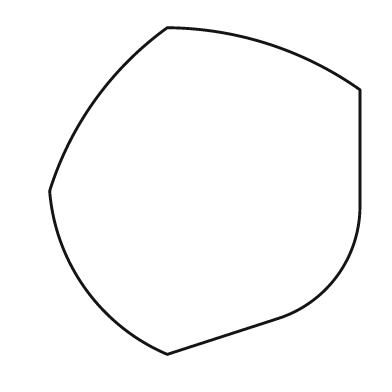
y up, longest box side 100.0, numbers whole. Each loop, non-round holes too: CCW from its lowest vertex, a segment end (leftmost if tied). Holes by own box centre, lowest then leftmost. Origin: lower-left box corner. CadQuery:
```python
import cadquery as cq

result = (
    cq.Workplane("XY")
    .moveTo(36.0, 0.0)
    .lineTo(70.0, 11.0)
    .threePointArc((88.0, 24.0), (95.0, 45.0))
    .lineTo(95.0, 81.0)
    .threePointArc((67.0, 95.0), (36.0, 100.0))
    .threePointArc((14.0, 78.0), (0.0, 50.0))
    .threePointArc((11.0, 20.0), (36.0, 0.0))
    .close()
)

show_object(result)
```